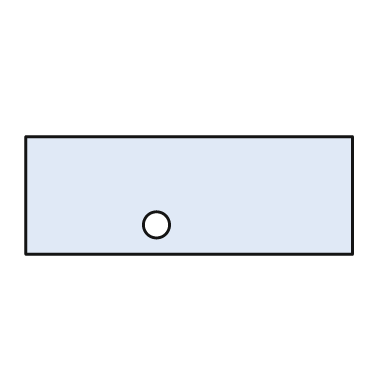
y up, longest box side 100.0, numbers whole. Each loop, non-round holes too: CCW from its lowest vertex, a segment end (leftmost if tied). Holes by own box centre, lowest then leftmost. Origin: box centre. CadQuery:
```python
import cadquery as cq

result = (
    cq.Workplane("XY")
    .moveTo(-50.0, -18.0)
    .lineTo(50.0, -18.0)
    .lineTo(50.0, 18.0)
    .lineTo(-50.0, 18.0)
    .close()
    .moveTo(-10.0, -9.0)
    .circle(4.0)
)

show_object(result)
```